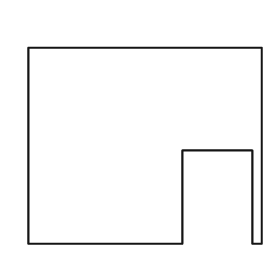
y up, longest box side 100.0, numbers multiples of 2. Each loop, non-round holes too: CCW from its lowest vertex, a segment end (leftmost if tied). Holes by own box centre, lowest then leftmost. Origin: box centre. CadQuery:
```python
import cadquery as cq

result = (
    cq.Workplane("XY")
    .moveTo(-50.0, -42.0)
    .lineTo(16.0, -42.0)
    .lineTo(16.0, -2.0)
    .lineTo(46.0, -2.0)
    .lineTo(46.0, -42.0)
    .lineTo(50.0, -42.0)
    .lineTo(50.0, 42.0)
    .lineTo(-50.0, 42.0)
    .close()
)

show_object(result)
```